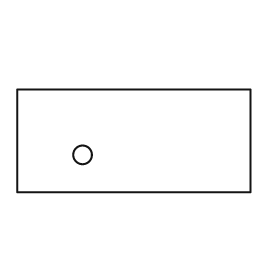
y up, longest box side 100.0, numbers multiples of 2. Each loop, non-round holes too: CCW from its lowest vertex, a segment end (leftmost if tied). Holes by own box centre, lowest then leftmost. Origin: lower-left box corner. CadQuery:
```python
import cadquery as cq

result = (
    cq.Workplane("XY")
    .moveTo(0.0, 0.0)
    .lineTo(100.0, 0.0)
    .lineTo(100.0, 44.0)
    .lineTo(0.0, 44.0)
    .close()
    .moveTo(28.0, 16.0)
    .circle(4.0)
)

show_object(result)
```